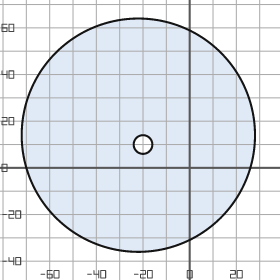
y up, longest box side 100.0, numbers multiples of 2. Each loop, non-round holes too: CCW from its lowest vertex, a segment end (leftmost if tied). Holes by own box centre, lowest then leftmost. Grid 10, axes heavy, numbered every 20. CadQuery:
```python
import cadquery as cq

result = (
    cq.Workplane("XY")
    .moveTo(-22.0, 14.0)
    .circle(50.0)
    .moveTo(-20.0, 10.0)
    .circle(4.0)
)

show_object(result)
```